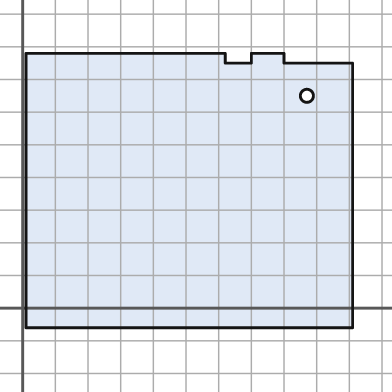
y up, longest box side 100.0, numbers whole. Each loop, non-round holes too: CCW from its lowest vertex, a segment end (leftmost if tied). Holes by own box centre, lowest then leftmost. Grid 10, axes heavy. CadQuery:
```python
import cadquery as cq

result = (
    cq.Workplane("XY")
    .moveTo(1.0, -6.0)
    .lineTo(101.0, -6.0)
    .lineTo(101.0, 75.0)
    .lineTo(80.0, 75.0)
    .lineTo(80.0, 78.0)
    .lineTo(70.0, 78.0)
    .lineTo(70.0, 75.0)
    .lineTo(62.0, 75.0)
    .lineTo(62.0, 78.0)
    .lineTo(1.0, 78.0)
    .close()
    .moveTo(87.0, 65.0)
    .circle(2.0)
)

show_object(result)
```